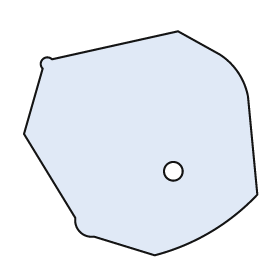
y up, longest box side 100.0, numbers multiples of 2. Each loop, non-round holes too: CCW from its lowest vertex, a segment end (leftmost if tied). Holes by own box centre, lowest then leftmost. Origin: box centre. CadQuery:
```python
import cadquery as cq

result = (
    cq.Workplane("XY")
    .moveTo(6.0, -48.0)
    .threePointArc((30.0, -38.0), (50.0, -22.0))
    .lineTo(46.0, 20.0)
    .threePointArc((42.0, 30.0), (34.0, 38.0))
    .lineTo(16.0, 48.0)
    .lineTo(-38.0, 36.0)
    .threePointArc((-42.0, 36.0), (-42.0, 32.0))
    .lineTo(-50.0, 4.0)
    .lineTo(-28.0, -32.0)
    .threePointArc((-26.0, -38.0), (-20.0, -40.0))
    .close()
    .moveTo(14.0, -12.0)
    .circle(4.0)
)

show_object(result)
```